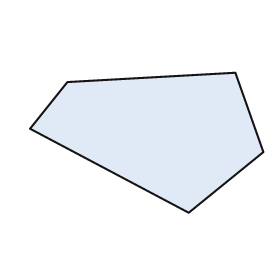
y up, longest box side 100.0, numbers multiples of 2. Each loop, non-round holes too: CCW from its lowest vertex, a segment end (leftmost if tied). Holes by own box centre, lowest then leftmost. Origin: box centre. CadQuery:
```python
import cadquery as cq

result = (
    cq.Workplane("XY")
    .moveTo(18.0, -30.0)
    .lineTo(50.0, -4.0)
    .lineTo(38.0, 30.0)
    .lineTo(-34.0, 26.0)
    .lineTo(-50.0, 6.0)
    .close()
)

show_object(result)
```